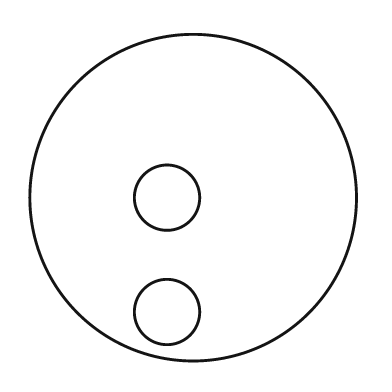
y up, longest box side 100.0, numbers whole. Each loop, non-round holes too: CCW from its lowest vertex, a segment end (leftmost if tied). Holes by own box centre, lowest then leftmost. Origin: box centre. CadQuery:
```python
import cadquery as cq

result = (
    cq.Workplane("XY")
    .moveTo(0.0, 0.0)
    .circle(50.0)
    .moveTo(-8.0, -35.0)
    .circle(10.0)
    .moveTo(-8.0, 0.0)
    .circle(10.0)
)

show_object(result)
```